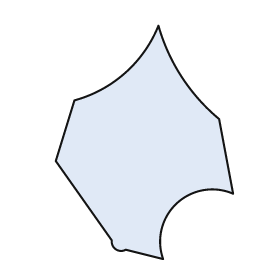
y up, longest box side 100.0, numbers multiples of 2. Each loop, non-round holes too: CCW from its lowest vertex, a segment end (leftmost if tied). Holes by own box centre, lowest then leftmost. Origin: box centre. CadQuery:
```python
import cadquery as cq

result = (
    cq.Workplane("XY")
    .moveTo(8.0, -50.0)
    .threePointArc((14.0, -26.0), (38.0, -22.0))
    .lineTo(32.0, 10.0)
    .threePointArc((16.0, 28.0), (6.0, 50.0))
    .threePointArc((-8.0, 30.0), (-30.0, 18.0))
    .lineTo(-38.0, -8.0)
    .lineTo(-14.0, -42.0)
    .threePointArc((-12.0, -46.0), (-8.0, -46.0))
    .close()
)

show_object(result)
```